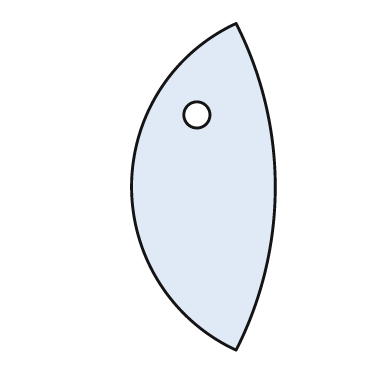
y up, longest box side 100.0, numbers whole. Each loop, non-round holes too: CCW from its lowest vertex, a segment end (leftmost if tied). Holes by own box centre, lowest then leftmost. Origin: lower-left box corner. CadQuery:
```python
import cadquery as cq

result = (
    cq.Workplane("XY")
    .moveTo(32.0, 0.0)
    .threePointArc((44.0, 50.0), (32.0, 100.0))
    .threePointArc((0.0, 50.0), (32.0, 0.0))
    .close()
    .moveTo(20.0, 72.0)
    .circle(4.0)
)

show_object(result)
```